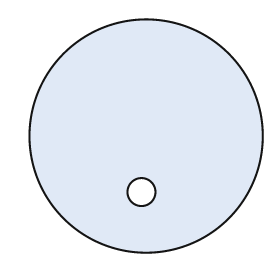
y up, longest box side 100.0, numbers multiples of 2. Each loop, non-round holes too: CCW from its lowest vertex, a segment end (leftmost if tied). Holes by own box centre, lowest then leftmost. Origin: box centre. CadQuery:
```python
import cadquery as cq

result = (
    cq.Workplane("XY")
    .moveTo(0.0, 0.0)
    .circle(50.0)
    .moveTo(-2.0, -24.0)
    .circle(6.0)
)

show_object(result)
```